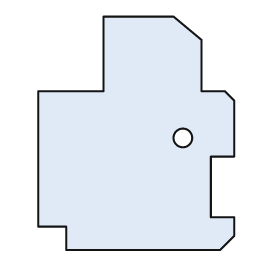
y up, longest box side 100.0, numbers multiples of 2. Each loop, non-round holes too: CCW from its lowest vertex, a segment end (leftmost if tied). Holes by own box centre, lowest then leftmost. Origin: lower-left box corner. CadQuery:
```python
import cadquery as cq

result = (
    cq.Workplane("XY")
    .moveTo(12.0, 0.0)
    .lineTo(78.0, 0.0)
    .lineTo(84.0, 6.0)
    .lineTo(84.0, 14.0)
    .lineTo(74.0, 14.0)
    .lineTo(74.0, 40.0)
    .lineTo(84.0, 40.0)
    .lineTo(84.0, 64.0)
    .lineTo(80.0, 68.0)
    .lineTo(70.0, 68.0)
    .lineTo(70.0, 90.0)
    .lineTo(58.0, 100.0)
    .lineTo(28.0, 100.0)
    .lineTo(28.0, 68.0)
    .lineTo(0.0, 68.0)
    .lineTo(0.0, 10.0)
    .lineTo(12.0, 10.0)
    .close()
    .moveTo(62.0, 48.0)
    .circle(4.0)
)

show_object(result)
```